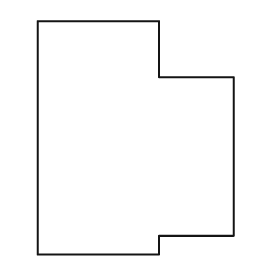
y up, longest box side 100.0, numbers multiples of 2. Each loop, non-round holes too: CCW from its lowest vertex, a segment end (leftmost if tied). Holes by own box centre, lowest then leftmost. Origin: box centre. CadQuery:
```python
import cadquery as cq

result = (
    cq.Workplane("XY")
    .moveTo(-42.0, -50.0)
    .lineTo(10.0, -50.0)
    .lineTo(10.0, -42.0)
    .lineTo(42.0, -42.0)
    .lineTo(42.0, 26.0)
    .lineTo(10.0, 26.0)
    .lineTo(10.0, 50.0)
    .lineTo(-42.0, 50.0)
    .close()
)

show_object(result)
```